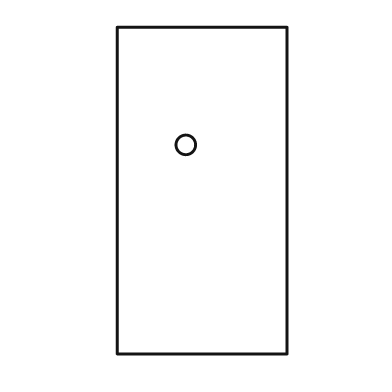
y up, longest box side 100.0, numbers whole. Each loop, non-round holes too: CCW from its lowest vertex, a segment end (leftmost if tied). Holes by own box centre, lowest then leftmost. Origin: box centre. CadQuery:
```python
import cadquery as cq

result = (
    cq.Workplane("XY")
    .moveTo(-26.0, -50.0)
    .lineTo(26.0, -50.0)
    .lineTo(26.0, 50.0)
    .lineTo(-26.0, 50.0)
    .close()
    .moveTo(-5.0, 14.0)
    .circle(3.0)
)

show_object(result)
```